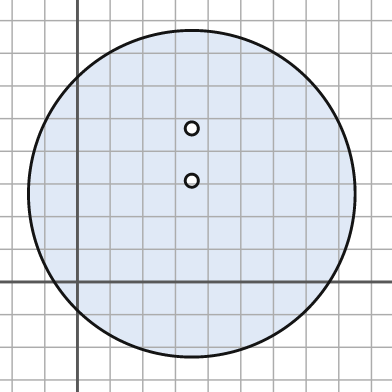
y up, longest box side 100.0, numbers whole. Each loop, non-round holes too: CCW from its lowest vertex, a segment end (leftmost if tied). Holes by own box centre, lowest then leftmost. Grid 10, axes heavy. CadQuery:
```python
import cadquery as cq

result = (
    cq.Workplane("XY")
    .moveTo(35.0, 27.0)
    .circle(50.0)
    .moveTo(35.0, 31.0)
    .circle(2.0)
    .moveTo(35.0, 47.0)
    .circle(2.0)
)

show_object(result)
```